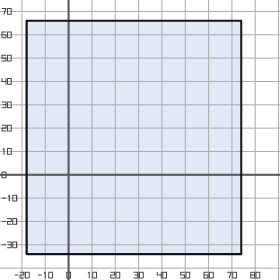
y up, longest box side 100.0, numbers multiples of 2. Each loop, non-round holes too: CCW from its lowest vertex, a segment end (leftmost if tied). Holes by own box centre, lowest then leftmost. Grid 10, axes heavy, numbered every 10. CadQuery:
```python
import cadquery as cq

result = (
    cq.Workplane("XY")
    .moveTo(-18.0, -34.0)
    .lineTo(74.0, -34.0)
    .lineTo(74.0, 66.0)
    .lineTo(-18.0, 66.0)
    .close()
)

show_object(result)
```